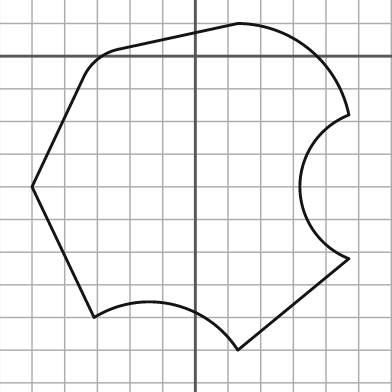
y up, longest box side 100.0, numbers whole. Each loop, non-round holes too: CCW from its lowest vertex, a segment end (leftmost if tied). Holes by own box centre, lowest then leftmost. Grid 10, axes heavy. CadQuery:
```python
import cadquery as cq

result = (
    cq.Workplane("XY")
    .moveTo(13.0, -90.0)
    .lineTo(47.0, -62.0)
    .threePointArc((32.0, -40.0), (47.0, -18.0))
    .threePointArc((35.0, 2.0), (13.0, 10.0))
    .lineTo(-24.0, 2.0)
    .threePointArc((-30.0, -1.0), (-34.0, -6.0))
    .lineTo(-50.0, -40.0)
    .lineTo(-31.0, -80.0)
    .threePointArc((-7.0, -76.0), (13.0, -90.0))
    .close()
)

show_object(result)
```